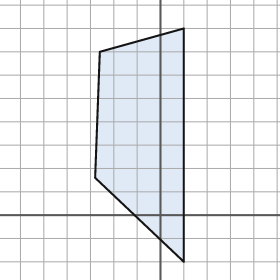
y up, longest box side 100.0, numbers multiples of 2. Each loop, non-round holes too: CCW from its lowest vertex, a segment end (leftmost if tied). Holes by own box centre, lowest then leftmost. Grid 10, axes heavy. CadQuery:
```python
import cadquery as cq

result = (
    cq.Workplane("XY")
    .moveTo(10.0, -20.0)
    .lineTo(10.0, 80.0)
    .lineTo(-26.0, 70.0)
    .lineTo(-28.0, 16.0)
    .close()
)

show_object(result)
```